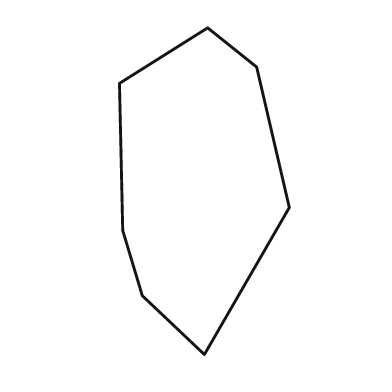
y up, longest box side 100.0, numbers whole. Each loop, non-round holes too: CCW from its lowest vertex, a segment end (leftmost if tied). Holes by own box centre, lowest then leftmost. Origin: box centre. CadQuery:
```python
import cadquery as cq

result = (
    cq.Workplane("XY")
    .moveTo(0.0, -50.0)
    .lineTo(26.0, -5.0)
    .lineTo(16.0, 38.0)
    .lineTo(1.0, 50.0)
    .lineTo(-26.0, 33.0)
    .lineTo(-25.0, -12.0)
    .lineTo(-19.0, -32.0)
    .close()
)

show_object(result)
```